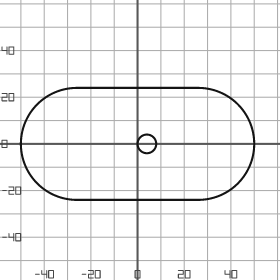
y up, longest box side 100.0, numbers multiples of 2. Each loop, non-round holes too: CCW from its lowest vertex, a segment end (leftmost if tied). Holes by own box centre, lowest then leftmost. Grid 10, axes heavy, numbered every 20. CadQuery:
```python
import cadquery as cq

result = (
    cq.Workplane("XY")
    .moveTo(-26.0, -24.0)
    .lineTo(26.0, -24.0)
    .threePointArc((50.0, 0.0), (26.0, 24.0))
    .lineTo(-26.0, 24.0)
    .threePointArc((-50.0, 0.0), (-26.0, -24.0))
    .close()
    .moveTo(4.0, 0.0)
    .circle(4.0)
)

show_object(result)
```